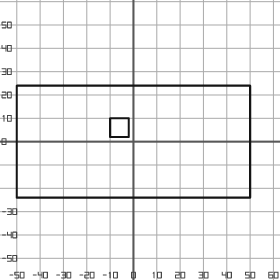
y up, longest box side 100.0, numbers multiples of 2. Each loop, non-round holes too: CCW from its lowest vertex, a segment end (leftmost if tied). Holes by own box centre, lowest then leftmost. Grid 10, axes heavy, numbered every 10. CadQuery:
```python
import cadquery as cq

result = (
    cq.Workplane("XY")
    .moveTo(-50.0, -24.0)
    .lineTo(50.0, -24.0)
    .lineTo(50.0, 24.0)
    .lineTo(-50.0, 24.0)
    .close()
    .moveTo(-10.0, 2.0)
    .lineTo(-2.0, 2.0)
    .lineTo(-2.0, 10.0)
    .lineTo(-10.0, 10.0)
    .close()
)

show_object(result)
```